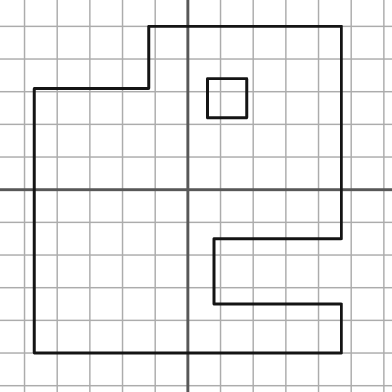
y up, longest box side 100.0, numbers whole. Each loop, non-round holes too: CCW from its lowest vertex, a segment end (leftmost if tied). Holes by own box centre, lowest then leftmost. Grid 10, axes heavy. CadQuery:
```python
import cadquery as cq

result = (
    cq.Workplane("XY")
    .moveTo(-47.0, -50.0)
    .lineTo(47.0, -50.0)
    .lineTo(47.0, -35.0)
    .lineTo(8.0, -35.0)
    .lineTo(8.0, -15.0)
    .lineTo(47.0, -15.0)
    .lineTo(47.0, 50.0)
    .lineTo(-12.0, 50.0)
    .lineTo(-12.0, 31.0)
    .lineTo(-47.0, 31.0)
    .close()
    .moveTo(6.0, 22.0)
    .lineTo(18.0, 22.0)
    .lineTo(18.0, 34.0)
    .lineTo(6.0, 34.0)
    .close()
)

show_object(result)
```